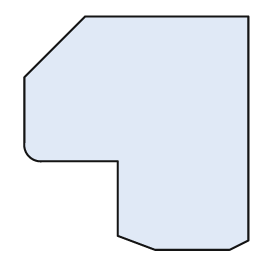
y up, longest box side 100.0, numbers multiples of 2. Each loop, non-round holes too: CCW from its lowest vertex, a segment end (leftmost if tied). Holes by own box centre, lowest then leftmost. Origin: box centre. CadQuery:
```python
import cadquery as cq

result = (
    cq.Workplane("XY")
    .moveTo(8.0, -50.0)
    .lineTo(40.0, -50.0)
    .lineTo(48.0, -46.0)
    .lineTo(48.0, 50.0)
    .lineTo(-22.0, 50.0)
    .lineTo(-48.0, 24.0)
    .lineTo(-48.0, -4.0)
    .threePointArc((-46.0, -10.0), (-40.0, -12.0))
    .lineTo(-8.0, -12.0)
    .lineTo(-8.0, -44.0)
    .close()
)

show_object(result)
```